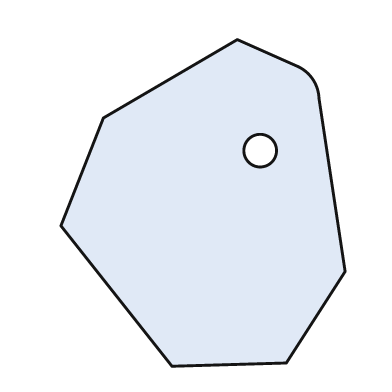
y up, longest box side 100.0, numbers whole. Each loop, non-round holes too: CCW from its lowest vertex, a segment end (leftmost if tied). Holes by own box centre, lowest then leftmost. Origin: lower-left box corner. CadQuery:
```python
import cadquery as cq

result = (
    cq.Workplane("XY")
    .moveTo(34.0, 0.0)
    .lineTo(69.0, 1.0)
    .lineTo(87.0, 29.0)
    .lineTo(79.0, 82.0)
    .threePointArc((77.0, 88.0), (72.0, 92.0))
    .lineTo(54.0, 100.0)
    .lineTo(13.0, 76.0)
    .lineTo(0.0, 43.0)
    .close()
    .moveTo(61.0, 66.0)
    .circle(5.0)
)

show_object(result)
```